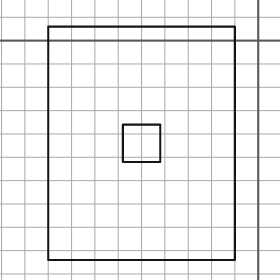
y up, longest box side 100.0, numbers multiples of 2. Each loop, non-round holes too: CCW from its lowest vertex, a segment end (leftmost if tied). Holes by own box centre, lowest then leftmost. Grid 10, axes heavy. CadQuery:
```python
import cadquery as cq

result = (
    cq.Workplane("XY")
    .moveTo(-90.0, -94.0)
    .lineTo(-10.0, -94.0)
    .lineTo(-10.0, 6.0)
    .lineTo(-90.0, 6.0)
    .close()
    .moveTo(-58.0, -52.0)
    .lineTo(-42.0, -52.0)
    .lineTo(-42.0, -36.0)
    .lineTo(-58.0, -36.0)
    .close()
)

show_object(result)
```